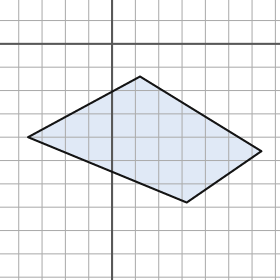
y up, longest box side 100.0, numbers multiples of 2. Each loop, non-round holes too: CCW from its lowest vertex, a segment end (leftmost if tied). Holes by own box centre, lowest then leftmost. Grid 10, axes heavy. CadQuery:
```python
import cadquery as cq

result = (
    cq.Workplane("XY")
    .moveTo(32.0, -68.0)
    .lineTo(64.0, -46.0)
    .lineTo(12.0, -14.0)
    .lineTo(-36.0, -40.0)
    .close()
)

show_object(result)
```